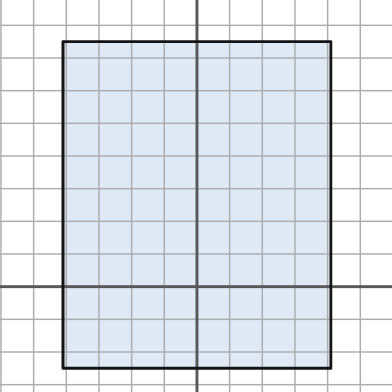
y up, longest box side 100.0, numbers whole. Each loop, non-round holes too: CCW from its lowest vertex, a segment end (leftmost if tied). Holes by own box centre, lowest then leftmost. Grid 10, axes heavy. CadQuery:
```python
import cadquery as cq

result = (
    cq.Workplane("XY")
    .moveTo(-41.0, -25.0)
    .lineTo(41.0, -25.0)
    .lineTo(41.0, 75.0)
    .lineTo(-41.0, 75.0)
    .close()
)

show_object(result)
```